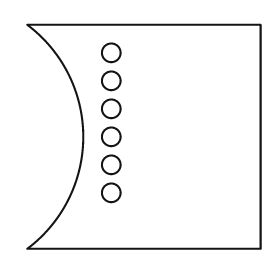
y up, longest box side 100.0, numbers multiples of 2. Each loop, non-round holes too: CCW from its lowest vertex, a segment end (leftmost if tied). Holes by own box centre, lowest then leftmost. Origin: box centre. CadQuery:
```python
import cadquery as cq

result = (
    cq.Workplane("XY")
    .moveTo(-50.0, -48.0)
    .lineTo(50.0, -48.0)
    .lineTo(50.0, 48.0)
    .lineTo(-50.0, 48.0)
    .threePointArc((-26.0, 0.0), (-50.0, -48.0))
    .close()
    .moveTo(-14.0, -24.0)
    .circle(4.0)
    .moveTo(-14.0, -12.0)
    .circle(4.0)
    .moveTo(-14.0, 0.0)
    .circle(4.0)
    .moveTo(-14.0, 12.0)
    .circle(4.0)
    .moveTo(-14.0, 24.0)
    .circle(4.0)
    .moveTo(-14.0, 36.0)
    .circle(4.0)
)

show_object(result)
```